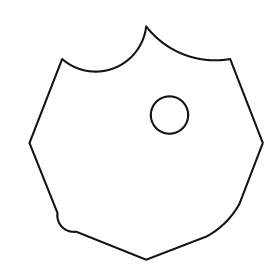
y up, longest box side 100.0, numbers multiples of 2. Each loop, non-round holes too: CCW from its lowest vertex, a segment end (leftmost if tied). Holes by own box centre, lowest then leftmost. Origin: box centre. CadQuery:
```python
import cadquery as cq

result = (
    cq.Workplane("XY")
    .moveTo(0.0, -50.0)
    .lineTo(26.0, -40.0)
    .threePointArc((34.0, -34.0), (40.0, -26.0))
    .lineTo(50.0, 0.0)
    .lineTo(36.0, 36.0)
    .threePointArc((16.0, 38.0), (0.0, 50.0))
    .threePointArc((-14.0, 32.0), (-36.0, 36.0))
    .lineTo(-50.0, 0.0)
    .lineTo(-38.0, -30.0)
    .threePointArc((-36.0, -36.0), (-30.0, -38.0))
    .close()
    .moveTo(10.0, 12.0)
    .circle(8.0)
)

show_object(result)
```